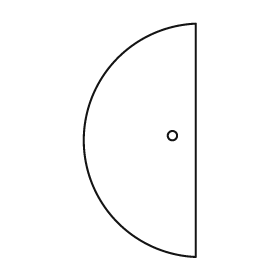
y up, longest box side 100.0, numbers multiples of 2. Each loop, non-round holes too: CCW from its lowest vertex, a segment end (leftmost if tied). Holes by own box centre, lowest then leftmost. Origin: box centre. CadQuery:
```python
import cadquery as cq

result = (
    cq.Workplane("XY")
    .moveTo(24.0, -50.0)
    .lineTo(24.0, 50.0)
    .threePointArc((-24.0, 0.0), (24.0, -50.0))
    .close()
    .moveTo(14.0, 2.0)
    .circle(2.0)
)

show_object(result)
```